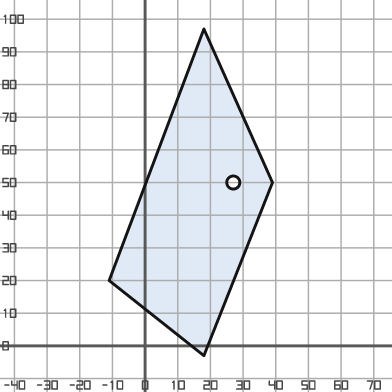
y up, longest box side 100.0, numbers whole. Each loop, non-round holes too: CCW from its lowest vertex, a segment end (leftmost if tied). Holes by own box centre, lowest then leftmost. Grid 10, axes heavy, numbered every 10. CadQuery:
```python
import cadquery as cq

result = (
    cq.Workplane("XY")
    .moveTo(18.0, -3.0)
    .lineTo(39.0, 50.0)
    .lineTo(18.0, 97.0)
    .lineTo(-11.0, 20.0)
    .close()
    .moveTo(27.0, 50.0)
    .circle(2.0)
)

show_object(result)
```